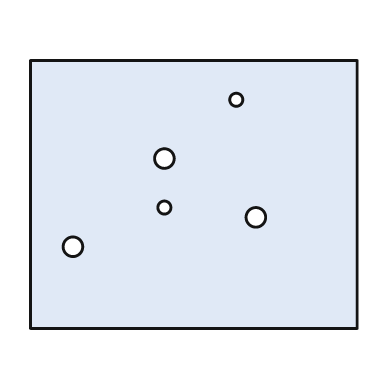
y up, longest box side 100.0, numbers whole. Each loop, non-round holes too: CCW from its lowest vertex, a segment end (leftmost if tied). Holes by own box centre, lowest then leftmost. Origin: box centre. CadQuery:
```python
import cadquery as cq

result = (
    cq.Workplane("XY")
    .moveTo(-50.0, -41.0)
    .lineTo(50.0, -41.0)
    .lineTo(50.0, 41.0)
    .lineTo(-50.0, 41.0)
    .close()
    .moveTo(-37.0, -16.0)
    .circle(3.0)
    .moveTo(19.0, -7.0)
    .circle(3.0)
    .moveTo(-9.0, -4.0)
    .circle(2.0)
    .moveTo(-9.0, 11.0)
    .circle(3.0)
    .moveTo(13.0, 29.0)
    .circle(2.0)
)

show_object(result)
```